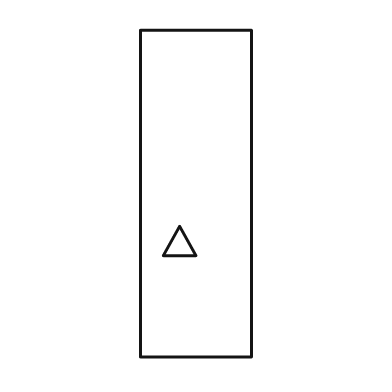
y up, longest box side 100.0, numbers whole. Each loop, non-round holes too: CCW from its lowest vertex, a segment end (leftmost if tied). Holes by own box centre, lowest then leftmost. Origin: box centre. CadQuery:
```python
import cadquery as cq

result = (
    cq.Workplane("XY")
    .moveTo(-17.0, -50.0)
    .lineTo(17.0, -50.0)
    .lineTo(17.0, 50.0)
    .lineTo(-17.0, 50.0)
    .close()
    .moveTo(-10.0, -19.0)
    .lineTo(0.0, -19.0)
    .lineTo(-5.0, -10.0)
    .close()
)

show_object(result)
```